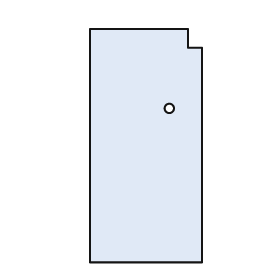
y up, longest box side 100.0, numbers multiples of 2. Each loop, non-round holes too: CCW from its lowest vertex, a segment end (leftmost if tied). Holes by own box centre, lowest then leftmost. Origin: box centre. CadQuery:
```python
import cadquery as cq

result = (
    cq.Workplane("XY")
    .moveTo(-24.0, -50.0)
    .lineTo(24.0, -50.0)
    .lineTo(24.0, 42.0)
    .lineTo(18.0, 42.0)
    .lineTo(18.0, 50.0)
    .lineTo(-24.0, 50.0)
    .close()
    .moveTo(10.0, 16.0)
    .circle(2.0)
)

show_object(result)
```